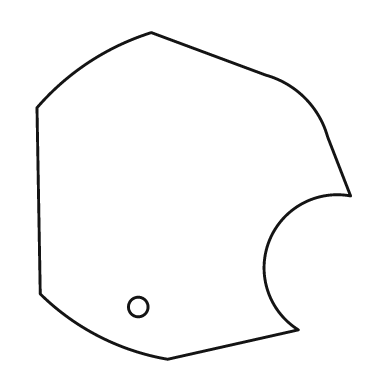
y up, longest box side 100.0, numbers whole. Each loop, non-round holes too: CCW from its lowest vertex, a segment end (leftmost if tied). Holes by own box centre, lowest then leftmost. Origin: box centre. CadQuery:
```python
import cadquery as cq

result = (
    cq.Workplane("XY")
    .moveTo(-8.0, -50.0)
    .lineTo(32.0, -41.0)
    .threePointArc((23.0, -14.0), (48.0, 0.0))
    .lineTo(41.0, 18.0)
    .threePointArc((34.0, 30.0), (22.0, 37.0))
    .lineTo(-13.0, 50.0)
    .threePointArc((-32.0, 41.0), (-48.0, 27.0))
    .lineTo(-47.0, -30.0)
    .threePointArc((-29.0, -43.0), (-8.0, -50.0))
    .close()
    .moveTo(-17.0, -34.0)
    .circle(3.0)
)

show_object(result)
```